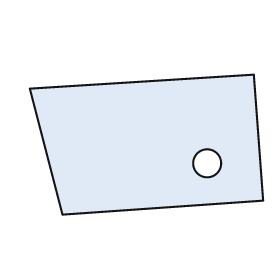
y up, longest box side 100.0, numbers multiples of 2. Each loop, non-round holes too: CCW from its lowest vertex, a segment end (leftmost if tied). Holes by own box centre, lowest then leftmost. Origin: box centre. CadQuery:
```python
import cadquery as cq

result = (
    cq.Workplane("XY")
    .moveTo(-36.0, -30.0)
    .lineTo(50.0, -24.0)
    .lineTo(46.0, 30.0)
    .lineTo(-50.0, 24.0)
    .close()
    .moveTo(26.0, -8.0)
    .circle(6.0)
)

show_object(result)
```